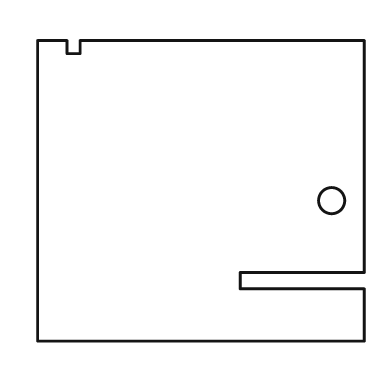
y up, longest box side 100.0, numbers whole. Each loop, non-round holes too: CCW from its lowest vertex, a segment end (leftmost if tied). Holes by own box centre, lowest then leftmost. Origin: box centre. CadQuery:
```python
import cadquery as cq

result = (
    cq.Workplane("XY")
    .moveTo(-50.0, -46.0)
    .lineTo(50.0, -46.0)
    .lineTo(50.0, -30.0)
    .lineTo(12.0, -30.0)
    .lineTo(12.0, -25.0)
    .lineTo(50.0, -25.0)
    .lineTo(50.0, 46.0)
    .lineTo(-37.0, 46.0)
    .lineTo(-37.0, 42.0)
    .lineTo(-41.0, 42.0)
    .lineTo(-41.0, 46.0)
    .lineTo(-50.0, 46.0)
    .close()
    .moveTo(40.0, -3.0)
    .circle(4.0)
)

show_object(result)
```